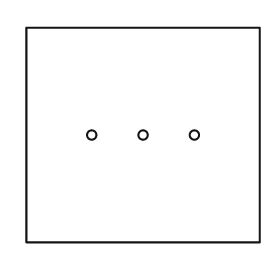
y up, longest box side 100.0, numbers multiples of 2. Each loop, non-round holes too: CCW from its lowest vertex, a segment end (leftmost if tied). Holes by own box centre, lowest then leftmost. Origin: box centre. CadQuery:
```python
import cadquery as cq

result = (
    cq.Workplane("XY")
    .moveTo(-50.0, -46.0)
    .lineTo(50.0, -46.0)
    .lineTo(50.0, 46.0)
    .lineTo(-50.0, 46.0)
    .close()
    .moveTo(-22.0, 0.0)
    .circle(2.0)
    .moveTo(0.0, 0.0)
    .circle(2.0)
    .moveTo(22.0, 0.0)
    .circle(2.0)
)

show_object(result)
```